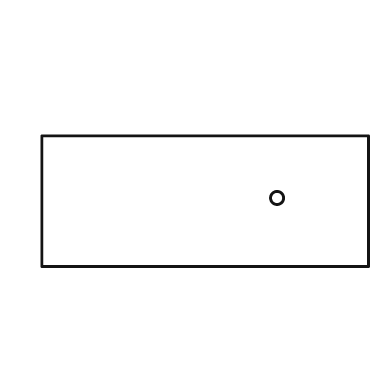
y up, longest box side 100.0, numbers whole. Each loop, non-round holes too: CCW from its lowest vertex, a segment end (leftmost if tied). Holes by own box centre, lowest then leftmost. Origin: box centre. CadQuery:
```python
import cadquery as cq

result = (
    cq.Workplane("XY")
    .moveTo(-50.0, -20.0)
    .lineTo(50.0, -20.0)
    .lineTo(50.0, 20.0)
    .lineTo(-50.0, 20.0)
    .close()
    .moveTo(22.0, 1.0)
    .circle(2.0)
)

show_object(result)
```